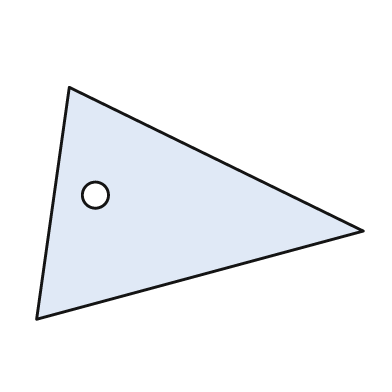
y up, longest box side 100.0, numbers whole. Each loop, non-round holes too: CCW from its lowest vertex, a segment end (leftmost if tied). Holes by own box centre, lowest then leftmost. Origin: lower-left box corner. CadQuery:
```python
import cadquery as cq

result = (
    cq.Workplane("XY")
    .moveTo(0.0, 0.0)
    .lineTo(100.0, 27.0)
    .lineTo(10.0, 71.0)
    .close()
    .moveTo(18.0, 38.0)
    .circle(4.0)
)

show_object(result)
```